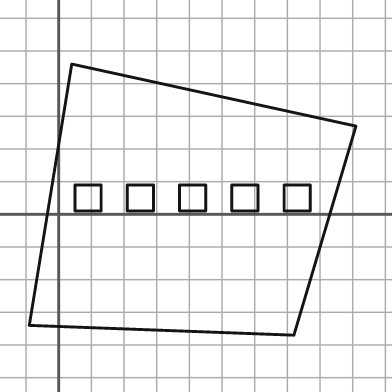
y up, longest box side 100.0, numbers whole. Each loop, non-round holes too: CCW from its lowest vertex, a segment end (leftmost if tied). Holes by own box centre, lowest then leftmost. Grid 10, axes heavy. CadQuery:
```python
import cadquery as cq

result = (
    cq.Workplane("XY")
    .moveTo(72.0, -37.0)
    .lineTo(91.0, 27.0)
    .lineTo(4.0, 46.0)
    .lineTo(-9.0, -34.0)
    .close()
    .moveTo(5.0, 1.0)
    .lineTo(13.0, 1.0)
    .lineTo(13.0, 9.0)
    .lineTo(5.0, 9.0)
    .close()
    .moveTo(21.0, 1.0)
    .lineTo(29.0, 1.0)
    .lineTo(29.0, 9.0)
    .lineTo(21.0, 9.0)
    .close()
    .moveTo(37.0, 1.0)
    .lineTo(45.0, 1.0)
    .lineTo(45.0, 9.0)
    .lineTo(37.0, 9.0)
    .close()
    .moveTo(53.0, 1.0)
    .lineTo(61.0, 1.0)
    .lineTo(61.0, 9.0)
    .lineTo(53.0, 9.0)
    .close()
    .moveTo(69.0, 1.0)
    .lineTo(77.0, 1.0)
    .lineTo(77.0, 9.0)
    .lineTo(69.0, 9.0)
    .close()
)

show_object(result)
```